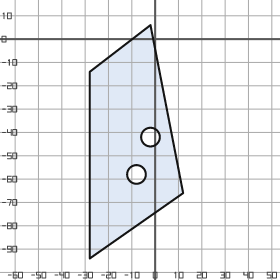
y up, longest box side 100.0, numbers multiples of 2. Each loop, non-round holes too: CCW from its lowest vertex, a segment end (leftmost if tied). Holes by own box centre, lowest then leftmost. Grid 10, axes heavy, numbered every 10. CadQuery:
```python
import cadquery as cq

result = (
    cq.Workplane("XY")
    .moveTo(-28.0, -94.0)
    .lineTo(12.0, -66.0)
    .lineTo(-2.0, 6.0)
    .lineTo(-28.0, -14.0)
    .close()
    .moveTo(-8.0, -58.0)
    .circle(4.0)
    .moveTo(-2.0, -42.0)
    .circle(4.0)
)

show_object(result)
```